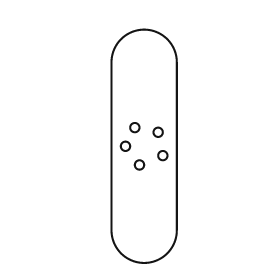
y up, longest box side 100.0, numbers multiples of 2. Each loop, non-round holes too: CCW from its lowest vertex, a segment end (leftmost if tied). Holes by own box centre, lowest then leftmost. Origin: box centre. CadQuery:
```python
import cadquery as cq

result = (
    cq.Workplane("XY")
    .moveTo(-14.0, -36.0)
    .threePointArc((0.0, -50.0), (14.0, -36.0))
    .lineTo(14.0, 36.0)
    .threePointArc((0.0, 50.0), (-14.0, 36.0))
    .close()
    .moveTo(-2.0, -8.0)
    .circle(2.0)
    .moveTo(8.0, -4.0)
    .circle(2.0)
    .moveTo(-8.0, 0.0)
    .circle(2.0)
    .moveTo(6.0, 6.0)
    .circle(2.0)
    .moveTo(-4.0, 8.0)
    .circle(2.0)
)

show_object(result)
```